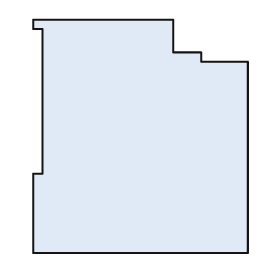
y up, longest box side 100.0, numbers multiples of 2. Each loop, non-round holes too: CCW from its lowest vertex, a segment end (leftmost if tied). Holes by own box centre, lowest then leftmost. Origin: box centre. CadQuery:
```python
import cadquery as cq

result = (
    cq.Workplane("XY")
    .moveTo(-46.0, -50.0)
    .lineTo(46.0, -50.0)
    .lineTo(46.0, 32.0)
    .lineTo(26.0, 32.0)
    .lineTo(26.0, 36.0)
    .lineTo(14.0, 36.0)
    .lineTo(14.0, 50.0)
    .lineTo(-46.0, 50.0)
    .lineTo(-46.0, 46.0)
    .lineTo(-42.0, 46.0)
    .lineTo(-42.0, -16.0)
    .lineTo(-46.0, -16.0)
    .close()
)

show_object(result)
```